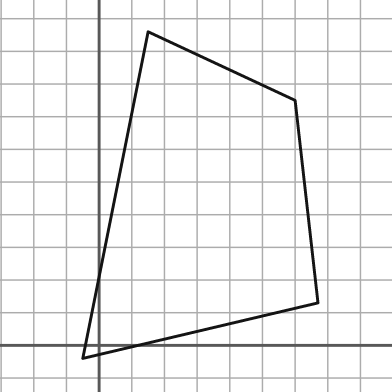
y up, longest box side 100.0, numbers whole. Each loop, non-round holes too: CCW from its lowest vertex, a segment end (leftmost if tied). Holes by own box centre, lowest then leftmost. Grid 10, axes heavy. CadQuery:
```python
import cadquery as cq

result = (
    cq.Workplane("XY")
    .moveTo(-5.0, -4.0)
    .lineTo(67.0, 13.0)
    .lineTo(60.0, 75.0)
    .lineTo(15.0, 96.0)
    .close()
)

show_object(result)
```